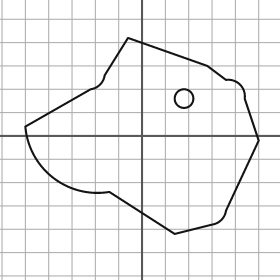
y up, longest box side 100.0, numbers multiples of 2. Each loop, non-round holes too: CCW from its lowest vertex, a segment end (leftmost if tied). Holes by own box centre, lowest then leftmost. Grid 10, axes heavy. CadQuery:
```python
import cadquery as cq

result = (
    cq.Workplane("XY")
    .moveTo(14.0, -42.0)
    .lineTo(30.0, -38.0)
    .threePointArc((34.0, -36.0), (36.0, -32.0))
    .lineTo(50.0, -2.0)
    .lineTo(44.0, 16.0)
    .threePointArc((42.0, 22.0), (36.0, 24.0))
    .lineTo(28.0, 30.0)
    .lineTo(-6.0, 42.0)
    .lineTo(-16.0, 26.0)
    .threePointArc((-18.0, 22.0), (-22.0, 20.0))
    .lineTo(-50.0, 4.0)
    .threePointArc((-38.0, -18.0), (-14.0, -24.0))
    .close()
    .moveTo(18.0, 16.0)
    .circle(4.0)
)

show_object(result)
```